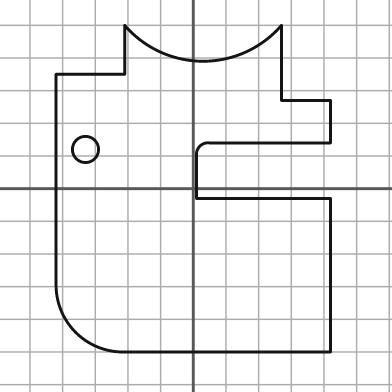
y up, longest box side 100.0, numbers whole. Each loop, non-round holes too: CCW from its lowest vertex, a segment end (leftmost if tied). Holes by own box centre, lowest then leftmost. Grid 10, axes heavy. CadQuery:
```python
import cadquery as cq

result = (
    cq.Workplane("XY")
    .moveTo(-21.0, -50.0)
    .lineTo(42.0, -50.0)
    .lineTo(42.0, -3.0)
    .lineTo(1.0, -3.0)
    .lineTo(1.0, 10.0)
    .threePointArc((2.0, 13.0), (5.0, 14.0))
    .lineTo(42.0, 14.0)
    .lineTo(42.0, 27.0)
    .lineTo(27.0, 27.0)
    .lineTo(27.0, 50.0)
    .threePointArc((3.0, 39.0), (-21.0, 50.0))
    .lineTo(-21.0, 35.0)
    .lineTo(-42.0, 35.0)
    .lineTo(-42.0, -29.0)
    .threePointArc((-36.0, -44.0), (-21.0, -50.0))
    .close()
    .moveTo(-33.0, 12.0)
    .circle(4.0)
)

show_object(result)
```